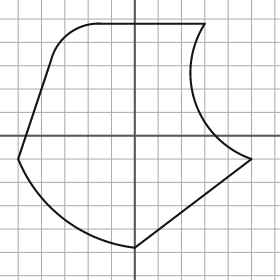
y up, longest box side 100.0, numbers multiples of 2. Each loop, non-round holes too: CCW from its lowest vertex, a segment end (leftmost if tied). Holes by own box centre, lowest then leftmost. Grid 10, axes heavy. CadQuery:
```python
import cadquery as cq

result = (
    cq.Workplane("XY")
    .moveTo(0.0, -48.0)
    .lineTo(50.0, -10.0)
    .threePointArc((26.0, 14.0), (30.0, 48.0))
    .lineTo(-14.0, 48.0)
    .threePointArc((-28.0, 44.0), (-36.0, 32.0))
    .lineTo(-50.0, -10.0)
    .threePointArc((-30.0, -36.0), (0.0, -48.0))
    .close()
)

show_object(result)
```